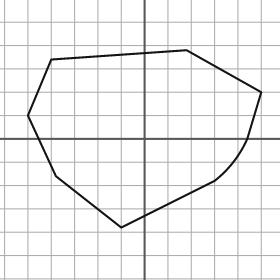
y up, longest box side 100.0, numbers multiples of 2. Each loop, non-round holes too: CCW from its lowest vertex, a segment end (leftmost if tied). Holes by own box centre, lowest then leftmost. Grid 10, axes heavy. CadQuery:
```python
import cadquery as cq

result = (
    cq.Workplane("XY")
    .moveTo(-10.0, -38.0)
    .lineTo(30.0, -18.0)
    .threePointArc((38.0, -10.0), (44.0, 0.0))
    .lineTo(50.0, 20.0)
    .lineTo(18.0, 38.0)
    .lineTo(-40.0, 34.0)
    .lineTo(-50.0, 10.0)
    .lineTo(-38.0, -16.0)
    .close()
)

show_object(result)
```